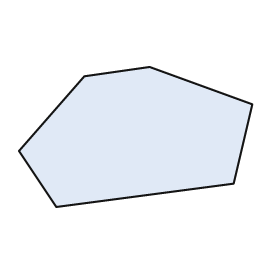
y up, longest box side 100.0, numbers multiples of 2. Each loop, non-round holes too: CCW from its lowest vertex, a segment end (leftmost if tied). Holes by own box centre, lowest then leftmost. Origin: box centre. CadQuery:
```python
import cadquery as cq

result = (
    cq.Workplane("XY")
    .moveTo(-34.0, -30.0)
    .lineTo(42.0, -20.0)
    .lineTo(50.0, 14.0)
    .lineTo(6.0, 30.0)
    .lineTo(-22.0, 26.0)
    .lineTo(-50.0, -6.0)
    .close()
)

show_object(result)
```